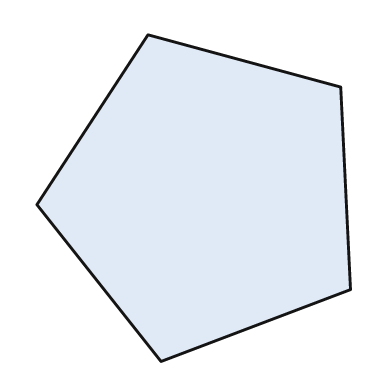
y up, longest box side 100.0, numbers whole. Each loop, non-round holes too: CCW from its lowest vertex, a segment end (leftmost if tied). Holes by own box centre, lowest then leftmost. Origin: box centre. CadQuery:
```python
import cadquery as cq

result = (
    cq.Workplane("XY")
    .moveTo(-10.0, -50.0)
    .lineTo(48.0, -28.0)
    .lineTo(45.0, 34.0)
    .lineTo(-14.0, 50.0)
    .lineTo(-48.0, -2.0)
    .close()
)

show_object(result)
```